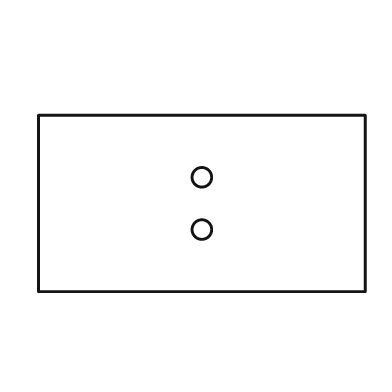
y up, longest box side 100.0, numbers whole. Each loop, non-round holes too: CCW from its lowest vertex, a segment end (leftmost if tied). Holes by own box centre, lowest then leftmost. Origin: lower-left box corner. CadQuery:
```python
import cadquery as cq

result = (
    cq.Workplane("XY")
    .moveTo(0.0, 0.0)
    .lineTo(100.0, 0.0)
    .lineTo(100.0, 54.0)
    .lineTo(0.0, 54.0)
    .close()
    .moveTo(50.0, 19.0)
    .circle(3.0)
    .moveTo(50.0, 35.0)
    .circle(3.0)
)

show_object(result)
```